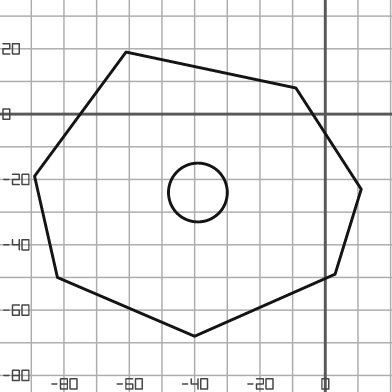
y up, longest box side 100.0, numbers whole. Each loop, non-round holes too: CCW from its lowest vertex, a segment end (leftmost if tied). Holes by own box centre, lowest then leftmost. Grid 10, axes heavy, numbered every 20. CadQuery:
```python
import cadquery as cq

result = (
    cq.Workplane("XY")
    .moveTo(-40.0, -68.0)
    .lineTo(3.0, -49.0)
    .lineTo(11.0, -23.0)
    .lineTo(-9.0, 8.0)
    .lineTo(-61.0, 19.0)
    .lineTo(-89.0, -19.0)
    .lineTo(-82.0, -50.0)
    .close()
    .moveTo(-39.0, -24.0)
    .circle(9.0)
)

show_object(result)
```